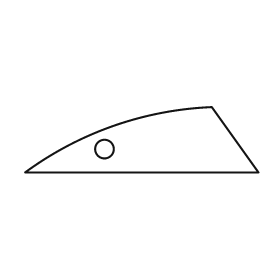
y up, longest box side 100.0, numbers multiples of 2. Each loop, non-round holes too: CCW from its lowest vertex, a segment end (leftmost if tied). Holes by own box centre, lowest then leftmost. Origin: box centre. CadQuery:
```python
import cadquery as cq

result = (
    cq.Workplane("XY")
    .moveTo(-50.0, -14.0)
    .lineTo(50.0, -14.0)
    .lineTo(30.0, 14.0)
    .threePointArc((-12.0, 6.0), (-50.0, -14.0))
    .close()
    .moveTo(-16.0, -4.0)
    .circle(4.0)
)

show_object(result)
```